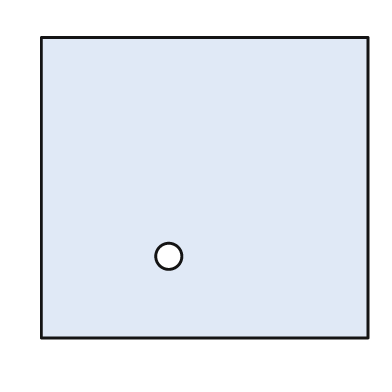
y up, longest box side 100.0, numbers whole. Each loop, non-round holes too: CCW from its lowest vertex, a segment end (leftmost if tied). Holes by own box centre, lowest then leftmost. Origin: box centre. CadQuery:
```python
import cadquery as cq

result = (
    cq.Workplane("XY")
    .moveTo(-50.0, -46.0)
    .lineTo(50.0, -46.0)
    .lineTo(50.0, 46.0)
    .lineTo(-50.0, 46.0)
    .close()
    .moveTo(-11.0, -21.0)
    .circle(4.0)
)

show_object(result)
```